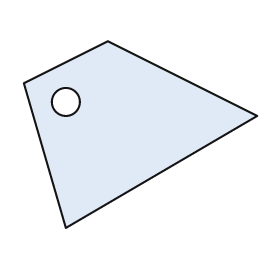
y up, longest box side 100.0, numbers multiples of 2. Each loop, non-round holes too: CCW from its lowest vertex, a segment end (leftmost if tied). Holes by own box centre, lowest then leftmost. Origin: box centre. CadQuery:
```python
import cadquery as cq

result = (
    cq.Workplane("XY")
    .moveTo(-32.0, -40.0)
    .lineTo(50.0, 8.0)
    .lineTo(-14.0, 40.0)
    .lineTo(-50.0, 22.0)
    .close()
    .moveTo(-32.0, 14.0)
    .circle(6.0)
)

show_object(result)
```